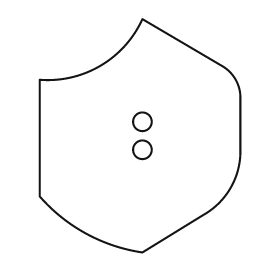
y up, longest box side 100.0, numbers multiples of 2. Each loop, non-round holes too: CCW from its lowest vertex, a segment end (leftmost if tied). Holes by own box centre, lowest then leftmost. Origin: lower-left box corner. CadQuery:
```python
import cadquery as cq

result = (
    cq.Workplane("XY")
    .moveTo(44.0, 0.0)
    .lineTo(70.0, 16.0)
    .threePointArc((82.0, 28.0), (86.0, 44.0))
    .lineTo(86.0, 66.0)
    .threePointArc((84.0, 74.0), (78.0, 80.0))
    .lineTo(44.0, 100.0)
    .threePointArc((26.0, 80.0), (0.0, 74.0))
    .lineTo(0.0, 24.0)
    .threePointArc((20.0, 8.0), (44.0, 0.0))
    .close()
    .moveTo(44.0, 44.0)
    .circle(4.0)
    .moveTo(44.0, 56.0)
    .circle(4.0)
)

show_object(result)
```